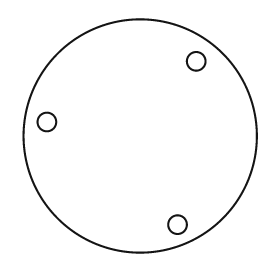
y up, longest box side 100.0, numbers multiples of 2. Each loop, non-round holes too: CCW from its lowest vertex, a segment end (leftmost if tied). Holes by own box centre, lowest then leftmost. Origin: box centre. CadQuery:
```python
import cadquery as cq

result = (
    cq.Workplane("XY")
    .moveTo(0.0, 0.0)
    .circle(50.0)
    .moveTo(16.0, -38.0)
    .circle(4.0)
    .moveTo(-40.0, 6.0)
    .circle(4.0)
    .moveTo(24.0, 32.0)
    .circle(4.0)
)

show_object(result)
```